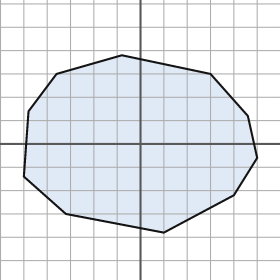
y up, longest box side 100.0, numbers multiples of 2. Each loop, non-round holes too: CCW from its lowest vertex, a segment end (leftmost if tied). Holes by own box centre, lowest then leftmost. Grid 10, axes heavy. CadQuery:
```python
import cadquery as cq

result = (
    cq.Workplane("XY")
    .moveTo(10.0, -38.0)
    .lineTo(40.0, -22.0)
    .lineTo(50.0, -6.0)
    .lineTo(46.0, 12.0)
    .lineTo(30.0, 30.0)
    .lineTo(-8.0, 38.0)
    .lineTo(-36.0, 30.0)
    .lineTo(-48.0, 14.0)
    .lineTo(-50.0, -14.0)
    .lineTo(-32.0, -30.0)
    .close()
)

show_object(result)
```